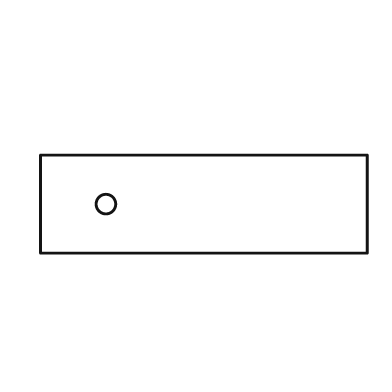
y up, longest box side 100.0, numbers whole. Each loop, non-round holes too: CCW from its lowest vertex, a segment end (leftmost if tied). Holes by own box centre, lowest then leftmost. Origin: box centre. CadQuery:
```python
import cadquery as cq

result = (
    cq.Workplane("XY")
    .moveTo(-50.0, -15.0)
    .lineTo(50.0, -15.0)
    .lineTo(50.0, 15.0)
    .lineTo(-50.0, 15.0)
    .close()
    .moveTo(-30.0, 0.0)
    .circle(3.0)
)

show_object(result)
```